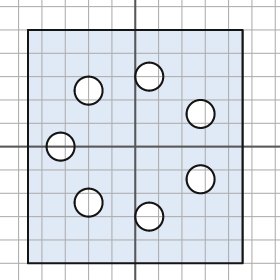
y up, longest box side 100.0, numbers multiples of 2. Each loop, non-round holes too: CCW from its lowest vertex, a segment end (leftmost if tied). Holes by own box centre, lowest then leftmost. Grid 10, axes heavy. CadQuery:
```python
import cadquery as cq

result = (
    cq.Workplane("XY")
    .moveTo(-46.0, -50.0)
    .lineTo(46.0, -50.0)
    .lineTo(46.0, 50.0)
    .lineTo(-46.0, 50.0)
    .close()
    .moveTo(6.0, -30.0)
    .circle(6.0)
    .moveTo(-20.0, -24.0)
    .circle(6.0)
    .moveTo(28.0, -14.0)
    .circle(6.0)
    .moveTo(-32.0, 0.0)
    .circle(6.0)
    .moveTo(28.0, 14.0)
    .circle(6.0)
    .moveTo(-20.0, 24.0)
    .circle(6.0)
    .moveTo(6.0, 30.0)
    .circle(6.0)
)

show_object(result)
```